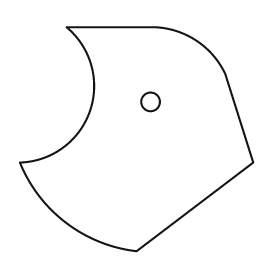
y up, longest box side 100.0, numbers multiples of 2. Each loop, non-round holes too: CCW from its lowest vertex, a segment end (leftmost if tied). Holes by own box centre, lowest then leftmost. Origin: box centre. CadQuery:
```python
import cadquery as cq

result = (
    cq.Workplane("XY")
    .moveTo(0.0, -48.0)
    .lineTo(50.0, -10.0)
    .lineTo(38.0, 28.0)
    .threePointArc((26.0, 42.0), (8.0, 48.0))
    .lineTo(-30.0, 48.0)
    .threePointArc((-20.0, 12.0), (-50.0, -10.0))
    .threePointArc((-30.0, -36.0), (0.0, -48.0))
    .close()
    .moveTo(6.0, 16.0)
    .circle(4.0)
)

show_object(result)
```